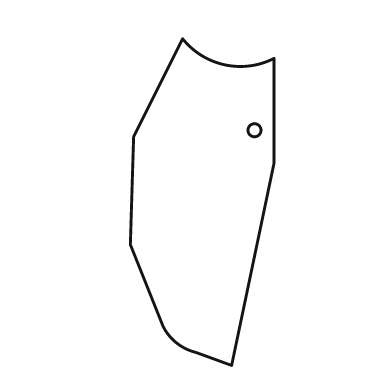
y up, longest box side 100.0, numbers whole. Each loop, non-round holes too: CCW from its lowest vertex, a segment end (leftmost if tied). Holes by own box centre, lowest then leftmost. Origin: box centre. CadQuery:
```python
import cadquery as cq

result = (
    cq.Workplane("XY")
    .moveTo(9.0, -50.0)
    .lineTo(22.0, 12.0)
    .lineTo(22.0, 44.0)
    .threePointArc((7.0, 42.0), (-6.0, 50.0))
    .lineTo(-21.0, 20.0)
    .lineTo(-22.0, -13.0)
    .lineTo(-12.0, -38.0)
    .threePointArc((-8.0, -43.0), (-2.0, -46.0))
    .close()
    .moveTo(16.0, 22.0)
    .circle(2.0)
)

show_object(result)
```